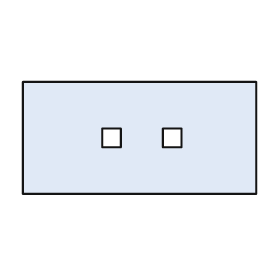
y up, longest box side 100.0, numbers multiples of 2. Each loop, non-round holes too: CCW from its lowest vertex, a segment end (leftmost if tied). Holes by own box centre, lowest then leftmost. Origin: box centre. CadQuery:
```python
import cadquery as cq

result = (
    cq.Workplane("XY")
    .moveTo(-50.0, -24.0)
    .lineTo(50.0, -24.0)
    .lineTo(50.0, 24.0)
    .lineTo(-50.0, 24.0)
    .close()
    .moveTo(-16.0, -4.0)
    .lineTo(-8.0, -4.0)
    .lineTo(-8.0, 4.0)
    .lineTo(-16.0, 4.0)
    .close()
    .moveTo(10.0, -4.0)
    .lineTo(18.0, -4.0)
    .lineTo(18.0, 4.0)
    .lineTo(10.0, 4.0)
    .close()
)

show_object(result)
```